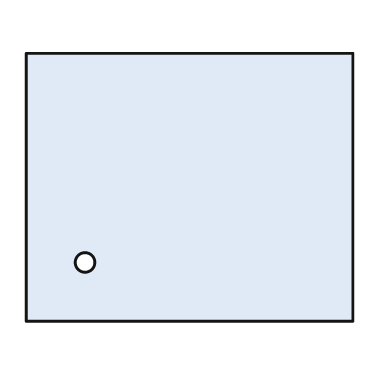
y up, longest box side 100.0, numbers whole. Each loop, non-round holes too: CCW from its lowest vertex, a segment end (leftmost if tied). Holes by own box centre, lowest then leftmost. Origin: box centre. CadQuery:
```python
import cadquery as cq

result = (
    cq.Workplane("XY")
    .moveTo(-50.0, -41.0)
    .lineTo(50.0, -41.0)
    .lineTo(50.0, 41.0)
    .lineTo(-50.0, 41.0)
    .close()
    .moveTo(-32.0, -23.0)
    .circle(3.0)
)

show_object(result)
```